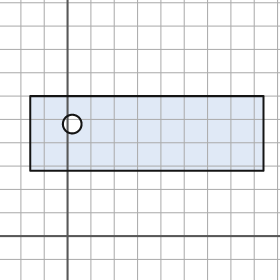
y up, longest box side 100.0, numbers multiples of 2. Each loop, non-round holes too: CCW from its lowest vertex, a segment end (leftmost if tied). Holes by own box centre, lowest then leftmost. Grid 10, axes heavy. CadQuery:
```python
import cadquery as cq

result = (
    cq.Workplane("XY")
    .moveTo(-16.0, 28.0)
    .lineTo(84.0, 28.0)
    .lineTo(84.0, 60.0)
    .lineTo(-16.0, 60.0)
    .close()
    .moveTo(2.0, 48.0)
    .circle(4.0)
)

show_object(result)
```